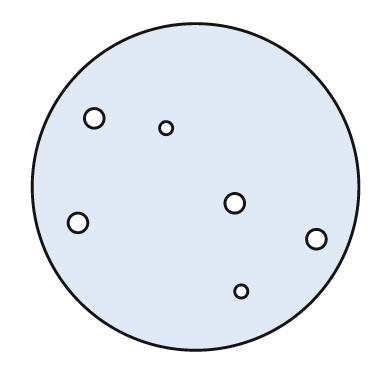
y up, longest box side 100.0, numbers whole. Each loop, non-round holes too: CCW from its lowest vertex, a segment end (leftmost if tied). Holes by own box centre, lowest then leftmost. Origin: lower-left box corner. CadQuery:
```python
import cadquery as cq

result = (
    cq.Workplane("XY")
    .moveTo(50.0, 50.0)
    .circle(50.0)
    .moveTo(64.0, 18.0)
    .circle(2.0)
    .moveTo(87.0, 34.0)
    .circle(3.0)
    .moveTo(14.0, 39.0)
    .circle(3.0)
    .moveTo(62.0, 45.0)
    .circle(3.0)
    .moveTo(41.0, 68.0)
    .circle(2.0)
    .moveTo(19.0, 71.0)
    .circle(3.0)
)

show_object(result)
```